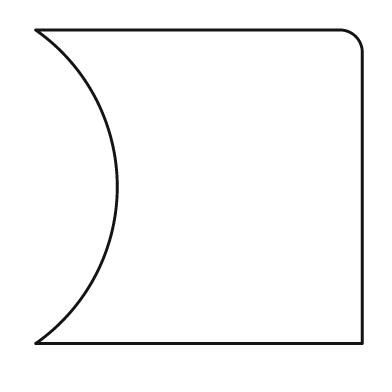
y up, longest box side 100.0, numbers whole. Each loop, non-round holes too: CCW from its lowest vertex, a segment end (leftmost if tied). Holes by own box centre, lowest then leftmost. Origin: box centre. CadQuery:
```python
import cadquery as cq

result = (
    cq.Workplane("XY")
    .moveTo(-50.0, -48.0)
    .lineTo(50.0, -48.0)
    .lineTo(50.0, 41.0)
    .threePointArc((48.0, 46.0), (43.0, 48.0))
    .lineTo(-50.0, 48.0)
    .threePointArc((-25.0, 0.0), (-50.0, -48.0))
    .close()
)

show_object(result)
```